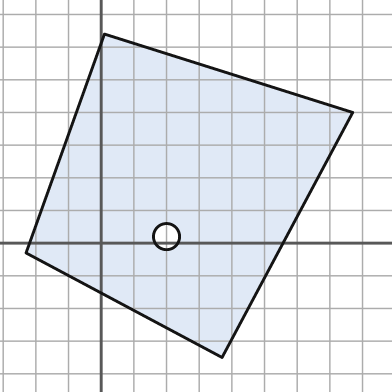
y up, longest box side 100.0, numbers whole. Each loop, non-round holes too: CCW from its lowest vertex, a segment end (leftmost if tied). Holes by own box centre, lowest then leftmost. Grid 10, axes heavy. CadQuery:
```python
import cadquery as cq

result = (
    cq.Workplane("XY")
    .moveTo(37.0, -35.0)
    .lineTo(77.0, 40.0)
    .lineTo(1.0, 64.0)
    .lineTo(-23.0, -3.0)
    .close()
    .moveTo(20.0, 2.0)
    .circle(4.0)
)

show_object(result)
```